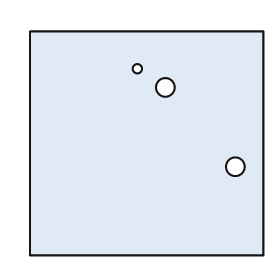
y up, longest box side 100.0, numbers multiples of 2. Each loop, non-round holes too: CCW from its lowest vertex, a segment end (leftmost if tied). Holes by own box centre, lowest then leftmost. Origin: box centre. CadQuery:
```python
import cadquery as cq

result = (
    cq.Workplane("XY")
    .moveTo(-50.0, -48.0)
    .lineTo(50.0, -48.0)
    .lineTo(50.0, 48.0)
    .lineTo(-50.0, 48.0)
    .close()
    .moveTo(38.0, -10.0)
    .circle(4.0)
    .moveTo(8.0, 24.0)
    .circle(4.0)
    .moveTo(-4.0, 32.0)
    .circle(2.0)
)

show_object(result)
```